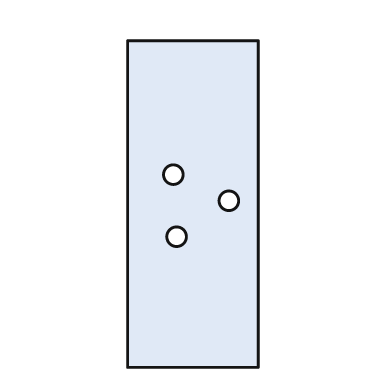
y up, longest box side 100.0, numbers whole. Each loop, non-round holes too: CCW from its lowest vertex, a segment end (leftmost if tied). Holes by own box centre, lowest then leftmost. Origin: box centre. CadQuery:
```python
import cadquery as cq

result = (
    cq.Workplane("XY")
    .moveTo(-20.0, -50.0)
    .lineTo(20.0, -50.0)
    .lineTo(20.0, 50.0)
    .lineTo(-20.0, 50.0)
    .close()
    .moveTo(-5.0, -10.0)
    .circle(3.0)
    .moveTo(11.0, 1.0)
    .circle(3.0)
    .moveTo(-6.0, 9.0)
    .circle(3.0)
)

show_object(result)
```